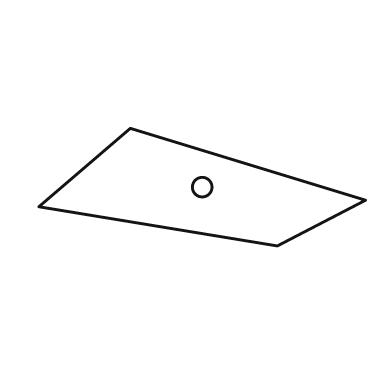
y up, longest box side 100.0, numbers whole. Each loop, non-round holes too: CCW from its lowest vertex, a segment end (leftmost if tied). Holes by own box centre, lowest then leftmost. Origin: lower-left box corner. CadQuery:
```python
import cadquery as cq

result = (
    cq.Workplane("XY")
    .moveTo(73.0, 0.0)
    .lineTo(100.0, 14.0)
    .lineTo(28.0, 36.0)
    .lineTo(0.0, 12.0)
    .close()
    .moveTo(50.0, 18.0)
    .circle(3.0)
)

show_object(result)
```